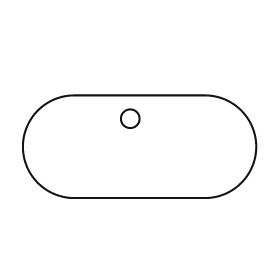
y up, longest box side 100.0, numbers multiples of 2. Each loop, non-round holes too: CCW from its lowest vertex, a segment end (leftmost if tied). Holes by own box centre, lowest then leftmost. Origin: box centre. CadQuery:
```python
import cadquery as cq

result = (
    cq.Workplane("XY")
    .moveTo(-28.0, -22.0)
    .lineTo(28.0, -22.0)
    .threePointArc((50.0, 0.0), (28.0, 22.0))
    .lineTo(-28.0, 22.0)
    .threePointArc((-50.0, 0.0), (-28.0, -22.0))
    .close()
    .moveTo(-4.0, 12.0)
    .circle(4.0)
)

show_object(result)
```